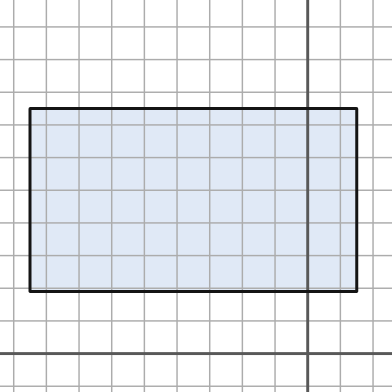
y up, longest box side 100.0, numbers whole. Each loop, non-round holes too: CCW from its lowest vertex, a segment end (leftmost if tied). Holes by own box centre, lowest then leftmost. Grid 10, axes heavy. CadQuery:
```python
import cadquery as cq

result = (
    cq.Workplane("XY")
    .moveTo(-85.0, 19.0)
    .lineTo(15.0, 19.0)
    .lineTo(15.0, 75.0)
    .lineTo(-85.0, 75.0)
    .close()
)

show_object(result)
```